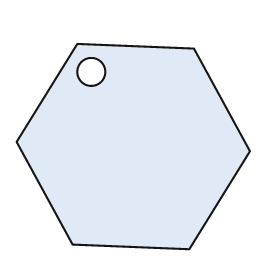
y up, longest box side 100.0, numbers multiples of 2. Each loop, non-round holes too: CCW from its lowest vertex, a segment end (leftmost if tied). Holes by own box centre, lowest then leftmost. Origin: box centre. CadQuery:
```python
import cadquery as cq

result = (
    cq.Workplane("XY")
    .moveTo(24.0, -44.0)
    .lineTo(50.0, -2.0)
    .lineTo(26.0, 42.0)
    .lineTo(-24.0, 44.0)
    .lineTo(-50.0, 2.0)
    .lineTo(-26.0, -42.0)
    .close()
    .moveTo(-18.0, 32.0)
    .circle(6.0)
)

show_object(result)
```